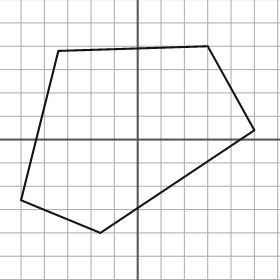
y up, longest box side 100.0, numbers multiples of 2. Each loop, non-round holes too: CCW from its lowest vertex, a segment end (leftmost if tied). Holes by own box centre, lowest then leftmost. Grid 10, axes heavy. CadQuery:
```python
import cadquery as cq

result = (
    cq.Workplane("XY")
    .moveTo(-16.0, -40.0)
    .lineTo(50.0, 4.0)
    .lineTo(30.0, 40.0)
    .lineTo(-34.0, 38.0)
    .lineTo(-50.0, -26.0)
    .close()
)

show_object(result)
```